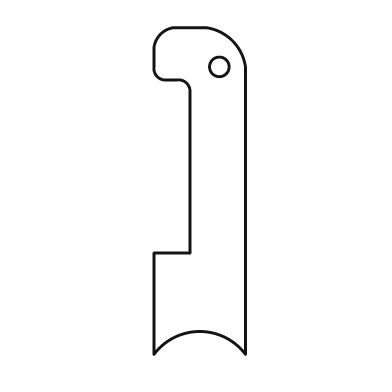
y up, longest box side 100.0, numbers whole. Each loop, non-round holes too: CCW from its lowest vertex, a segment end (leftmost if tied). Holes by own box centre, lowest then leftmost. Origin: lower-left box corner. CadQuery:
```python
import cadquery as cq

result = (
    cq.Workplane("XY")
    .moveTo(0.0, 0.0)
    .threePointArc((14.0, 7.0), (28.0, 0.0))
    .lineTo(28.0, 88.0)
    .threePointArc((24.0, 96.0), (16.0, 100.0))
    .lineTo(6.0, 100.0)
    .threePointArc((2.0, 98.0), (0.0, 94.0))
    .lineTo(0.0, 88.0)
    .threePointArc((1.0, 85.0), (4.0, 84.0))
    .lineTo(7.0, 84.0)
    .threePointArc((10.0, 83.0), (11.0, 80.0))
    .lineTo(11.0, 31.0)
    .lineTo(0.0, 31.0)
    .close()
    .moveTo(20.0, 88.0)
    .circle(3.0)
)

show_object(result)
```